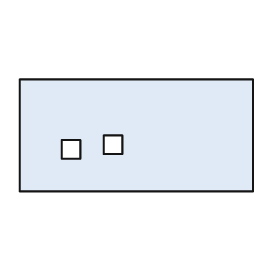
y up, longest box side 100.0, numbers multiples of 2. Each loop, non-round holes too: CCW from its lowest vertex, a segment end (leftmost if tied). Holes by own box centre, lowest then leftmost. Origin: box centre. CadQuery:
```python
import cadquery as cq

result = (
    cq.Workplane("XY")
    .moveTo(-50.0, -24.0)
    .lineTo(50.0, -24.0)
    .lineTo(50.0, 24.0)
    .lineTo(-50.0, 24.0)
    .close()
    .moveTo(-32.0, -10.0)
    .lineTo(-24.0, -10.0)
    .lineTo(-24.0, -2.0)
    .lineTo(-32.0, -2.0)
    .close()
    .moveTo(-14.0, -8.0)
    .lineTo(-6.0, -8.0)
    .lineTo(-6.0, 0.0)
    .lineTo(-14.0, 0.0)
    .close()
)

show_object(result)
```